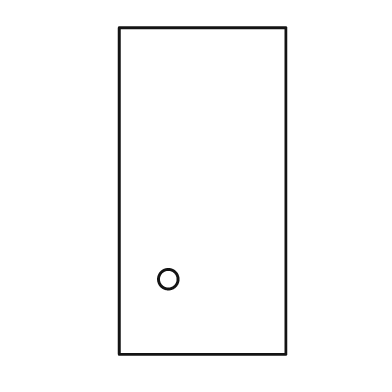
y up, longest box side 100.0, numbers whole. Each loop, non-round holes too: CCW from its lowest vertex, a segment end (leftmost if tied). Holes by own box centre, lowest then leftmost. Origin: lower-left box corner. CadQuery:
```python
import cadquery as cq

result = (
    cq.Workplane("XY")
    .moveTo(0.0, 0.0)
    .lineTo(51.0, 0.0)
    .lineTo(51.0, 100.0)
    .lineTo(0.0, 100.0)
    .close()
    .moveTo(15.0, 23.0)
    .circle(3.0)
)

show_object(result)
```